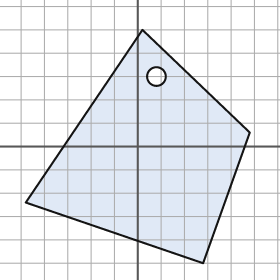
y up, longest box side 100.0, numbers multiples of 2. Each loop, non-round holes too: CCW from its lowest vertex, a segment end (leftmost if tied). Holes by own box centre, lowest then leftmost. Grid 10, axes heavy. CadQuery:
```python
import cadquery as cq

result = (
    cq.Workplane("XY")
    .moveTo(28.0, -50.0)
    .lineTo(48.0, 6.0)
    .lineTo(2.0, 50.0)
    .lineTo(-48.0, -24.0)
    .close()
    .moveTo(8.0, 30.0)
    .circle(4.0)
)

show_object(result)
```